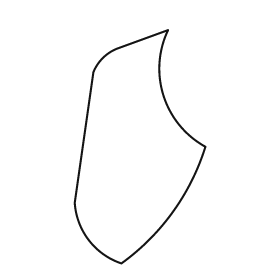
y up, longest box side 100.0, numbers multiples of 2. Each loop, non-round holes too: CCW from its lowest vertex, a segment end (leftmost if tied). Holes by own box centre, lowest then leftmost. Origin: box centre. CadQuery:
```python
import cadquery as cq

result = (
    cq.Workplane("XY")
    .moveTo(-8.0, -50.0)
    .threePointArc((14.0, -28.0), (28.0, 0.0))
    .threePointArc((10.0, 22.0), (12.0, 50.0))
    .lineTo(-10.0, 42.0)
    .threePointArc((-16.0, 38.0), (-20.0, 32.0))
    .lineTo(-28.0, -24.0)
    .threePointArc((-22.0, -40.0), (-8.0, -50.0))
    .close()
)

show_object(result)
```